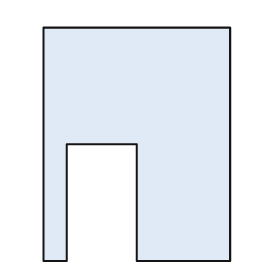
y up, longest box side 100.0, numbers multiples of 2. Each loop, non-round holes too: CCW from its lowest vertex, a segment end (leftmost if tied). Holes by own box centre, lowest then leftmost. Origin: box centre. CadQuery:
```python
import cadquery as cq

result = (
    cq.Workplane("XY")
    .moveTo(-40.0, -50.0)
    .lineTo(-30.0, -50.0)
    .lineTo(-30.0, 0.0)
    .lineTo(0.0, 0.0)
    .lineTo(0.0, -50.0)
    .lineTo(40.0, -50.0)
    .lineTo(40.0, 50.0)
    .lineTo(-40.0, 50.0)
    .close()
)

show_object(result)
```